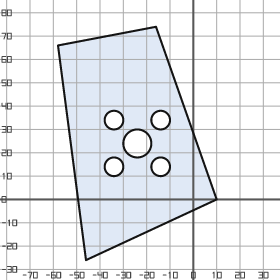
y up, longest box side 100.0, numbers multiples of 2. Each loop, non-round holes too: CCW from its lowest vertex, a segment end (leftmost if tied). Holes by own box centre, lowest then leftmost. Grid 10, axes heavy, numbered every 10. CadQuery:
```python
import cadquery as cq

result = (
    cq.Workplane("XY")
    .moveTo(-46.0, -26.0)
    .lineTo(10.0, 0.0)
    .lineTo(-16.0, 74.0)
    .lineTo(-58.0, 66.0)
    .close()
    .moveTo(-34.0, 14.0)
    .circle(4.0)
    .moveTo(-14.0, 14.0)
    .circle(4.0)
    .moveTo(-24.0, 24.0)
    .circle(6.0)
    .moveTo(-34.0, 34.0)
    .circle(4.0)
    .moveTo(-14.0, 34.0)
    .circle(4.0)
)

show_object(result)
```